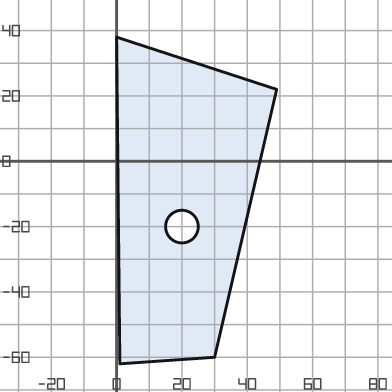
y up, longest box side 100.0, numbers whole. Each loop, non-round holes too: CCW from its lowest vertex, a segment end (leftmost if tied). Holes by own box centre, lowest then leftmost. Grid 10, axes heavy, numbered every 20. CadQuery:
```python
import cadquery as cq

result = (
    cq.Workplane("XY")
    .moveTo(1.0, -62.0)
    .lineTo(30.0, -60.0)
    .lineTo(49.0, 22.0)
    .lineTo(0.0, 38.0)
    .close()
    .moveTo(20.0, -20.0)
    .circle(5.0)
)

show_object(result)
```